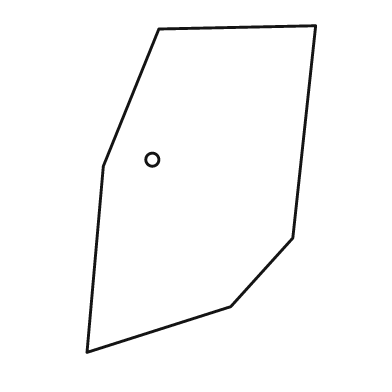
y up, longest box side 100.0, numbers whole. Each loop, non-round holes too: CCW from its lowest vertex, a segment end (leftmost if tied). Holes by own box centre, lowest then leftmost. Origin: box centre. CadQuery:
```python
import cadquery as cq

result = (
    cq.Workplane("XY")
    .moveTo(-35.0, -50.0)
    .lineTo(9.0, -36.0)
    .lineTo(28.0, -15.0)
    .lineTo(35.0, 50.0)
    .lineTo(-13.0, 49.0)
    .lineTo(-30.0, 7.0)
    .close()
    .moveTo(-15.0, 9.0)
    .circle(2.0)
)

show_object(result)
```